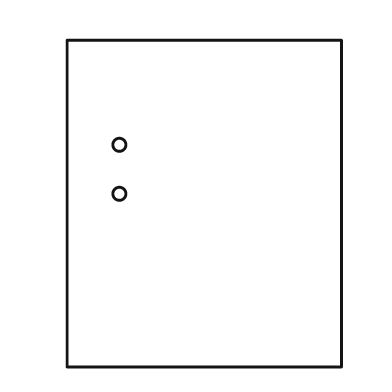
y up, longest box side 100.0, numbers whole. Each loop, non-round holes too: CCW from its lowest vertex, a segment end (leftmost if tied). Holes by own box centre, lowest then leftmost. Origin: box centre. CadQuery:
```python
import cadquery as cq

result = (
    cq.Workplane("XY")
    .moveTo(-42.0, -50.0)
    .lineTo(42.0, -50.0)
    .lineTo(42.0, 50.0)
    .lineTo(-42.0, 50.0)
    .close()
    .moveTo(-26.0, 3.0)
    .circle(2.0)
    .moveTo(-26.0, 18.0)
    .circle(2.0)
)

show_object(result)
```